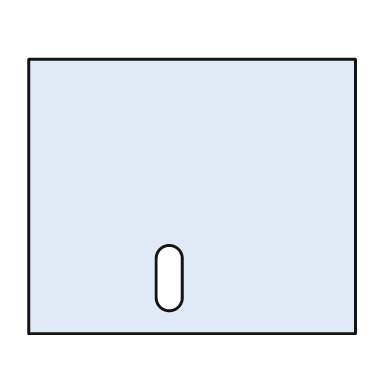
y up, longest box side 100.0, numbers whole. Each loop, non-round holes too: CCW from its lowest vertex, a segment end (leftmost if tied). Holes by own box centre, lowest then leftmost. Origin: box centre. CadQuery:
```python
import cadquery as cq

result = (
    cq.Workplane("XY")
    .moveTo(-50.0, -42.0)
    .lineTo(50.0, -42.0)
    .lineTo(50.0, 42.0)
    .lineTo(-50.0, 42.0)
    .close()
    .moveTo(-11.0, -31.0)
    .threePointArc((-7.0, -35.0), (-3.0, -31.0))
    .lineTo(-3.0, -19.0)
    .threePointArc((-7.0, -15.0), (-11.0, -19.0))
    .close()
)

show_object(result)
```